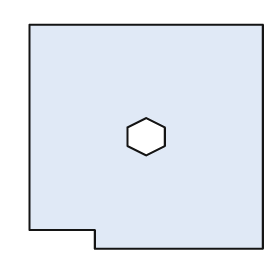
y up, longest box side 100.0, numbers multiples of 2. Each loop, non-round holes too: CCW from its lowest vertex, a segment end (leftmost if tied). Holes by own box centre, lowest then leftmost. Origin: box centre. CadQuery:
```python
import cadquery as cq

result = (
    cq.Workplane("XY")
    .moveTo(-22.0, -48.0)
    .lineTo(50.0, -48.0)
    .lineTo(50.0, 48.0)
    .lineTo(-50.0, 48.0)
    .lineTo(-50.0, -40.0)
    .lineTo(-22.0, -40.0)
    .close()
    .moveTo(0.0, -8.0)
    .lineTo(8.0, -4.0)
    .lineTo(8.0, 4.0)
    .lineTo(0.0, 8.0)
    .lineTo(-8.0, 4.0)
    .lineTo(-8.0, -4.0)
    .close()
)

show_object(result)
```